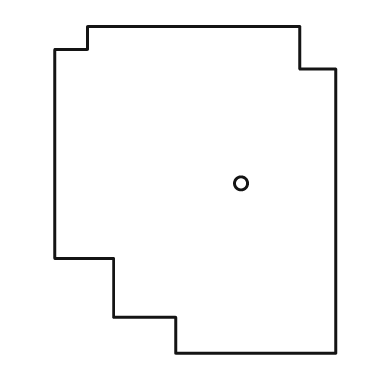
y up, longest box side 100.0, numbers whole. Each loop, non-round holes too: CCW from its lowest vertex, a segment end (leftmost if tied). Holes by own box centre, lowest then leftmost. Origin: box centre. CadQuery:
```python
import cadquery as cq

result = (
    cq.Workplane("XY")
    .moveTo(-6.0, -50.0)
    .lineTo(43.0, -50.0)
    .lineTo(43.0, 37.0)
    .lineTo(32.0, 37.0)
    .lineTo(32.0, 50.0)
    .lineTo(-33.0, 50.0)
    .lineTo(-33.0, 43.0)
    .lineTo(-43.0, 43.0)
    .lineTo(-43.0, -21.0)
    .lineTo(-25.0, -21.0)
    .lineTo(-25.0, -39.0)
    .lineTo(-6.0, -39.0)
    .close()
    .moveTo(14.0, 2.0)
    .circle(2.0)
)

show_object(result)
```